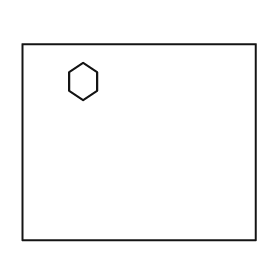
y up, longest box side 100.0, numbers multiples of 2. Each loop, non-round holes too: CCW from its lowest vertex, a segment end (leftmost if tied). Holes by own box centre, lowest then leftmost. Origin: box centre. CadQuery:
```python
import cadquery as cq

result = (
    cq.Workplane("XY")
    .moveTo(-50.0, -42.0)
    .lineTo(50.0, -42.0)
    .lineTo(50.0, 42.0)
    .lineTo(-50.0, 42.0)
    .close()
    .moveTo(-24.0, 18.0)
    .lineTo(-18.0, 22.0)
    .lineTo(-18.0, 30.0)
    .lineTo(-24.0, 34.0)
    .lineTo(-30.0, 30.0)
    .lineTo(-30.0, 22.0)
    .close()
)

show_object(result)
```